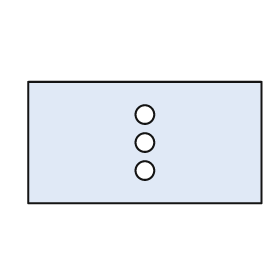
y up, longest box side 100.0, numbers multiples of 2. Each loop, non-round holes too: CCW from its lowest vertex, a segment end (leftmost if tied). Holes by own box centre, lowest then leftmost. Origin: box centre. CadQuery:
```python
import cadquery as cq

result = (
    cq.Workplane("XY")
    .moveTo(-50.0, -26.0)
    .lineTo(50.0, -26.0)
    .lineTo(50.0, 26.0)
    .lineTo(-50.0, 26.0)
    .close()
    .moveTo(0.0, -12.0)
    .circle(4.0)
    .moveTo(0.0, 0.0)
    .circle(4.0)
    .moveTo(0.0, 12.0)
    .circle(4.0)
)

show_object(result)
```